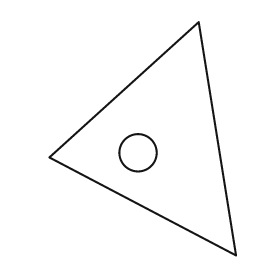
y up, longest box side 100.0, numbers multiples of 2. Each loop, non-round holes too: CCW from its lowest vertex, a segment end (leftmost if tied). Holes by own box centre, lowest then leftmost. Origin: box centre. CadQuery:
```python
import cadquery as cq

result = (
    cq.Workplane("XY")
    .moveTo(40.0, -50.0)
    .lineTo(24.0, 50.0)
    .lineTo(-40.0, -8.0)
    .close()
    .moveTo(-2.0, -6.0)
    .circle(8.0)
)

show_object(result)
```